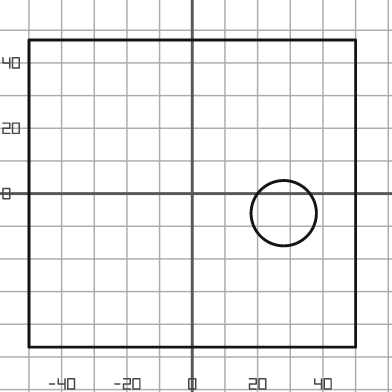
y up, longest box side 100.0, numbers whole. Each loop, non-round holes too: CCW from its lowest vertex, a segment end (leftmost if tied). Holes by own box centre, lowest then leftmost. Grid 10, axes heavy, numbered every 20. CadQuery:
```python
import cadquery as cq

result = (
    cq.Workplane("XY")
    .moveTo(-50.0, -47.0)
    .lineTo(50.0, -47.0)
    .lineTo(50.0, 47.0)
    .lineTo(-50.0, 47.0)
    .close()
    .moveTo(28.0, -6.0)
    .circle(10.0)
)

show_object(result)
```